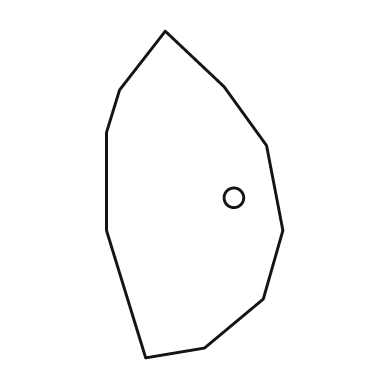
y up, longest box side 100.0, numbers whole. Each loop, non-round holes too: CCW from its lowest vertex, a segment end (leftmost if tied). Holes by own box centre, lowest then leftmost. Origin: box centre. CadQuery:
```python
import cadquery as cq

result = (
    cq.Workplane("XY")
    .moveTo(-15.0, -50.0)
    .lineTo(3.0, -47.0)
    .lineTo(21.0, -32.0)
    .lineTo(27.0, -11.0)
    .lineTo(22.0, 15.0)
    .lineTo(9.0, 33.0)
    .lineTo(-9.0, 50.0)
    .lineTo(-23.0, 32.0)
    .lineTo(-27.0, 19.0)
    .lineTo(-27.0, -11.0)
    .close()
    .moveTo(12.0, -1.0)
    .circle(3.0)
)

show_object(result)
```